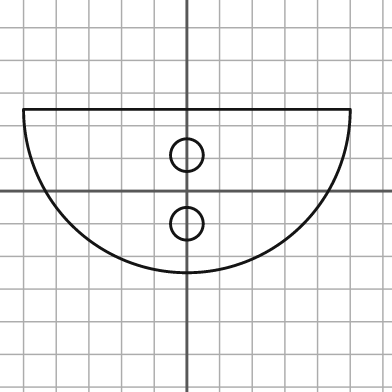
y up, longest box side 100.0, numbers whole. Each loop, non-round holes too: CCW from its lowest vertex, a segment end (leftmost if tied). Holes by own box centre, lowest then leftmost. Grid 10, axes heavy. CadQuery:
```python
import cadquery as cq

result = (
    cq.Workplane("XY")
    .moveTo(-50.0, 25.0)
    .threePointArc((0.0, -25.0), (50.0, 25.0))
    .close()
    .moveTo(0.0, -10.0)
    .circle(5.0)
    .moveTo(0.0, 11.0)
    .circle(5.0)
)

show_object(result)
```